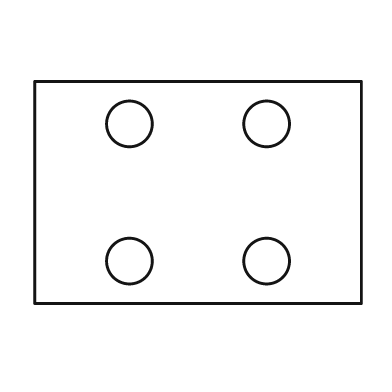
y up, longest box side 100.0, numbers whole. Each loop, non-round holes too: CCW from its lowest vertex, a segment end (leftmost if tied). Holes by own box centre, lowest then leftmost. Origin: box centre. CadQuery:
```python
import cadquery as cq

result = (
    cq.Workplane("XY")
    .moveTo(-50.0, -34.0)
    .lineTo(50.0, -34.0)
    .lineTo(50.0, 34.0)
    .lineTo(-50.0, 34.0)
    .close()
    .moveTo(-21.0, -21.0)
    .circle(7.0)
    .moveTo(21.0, -21.0)
    .circle(7.0)
    .moveTo(-21.0, 21.0)
    .circle(7.0)
    .moveTo(21.0, 21.0)
    .circle(7.0)
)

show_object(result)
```